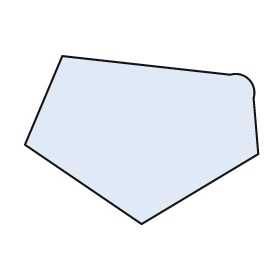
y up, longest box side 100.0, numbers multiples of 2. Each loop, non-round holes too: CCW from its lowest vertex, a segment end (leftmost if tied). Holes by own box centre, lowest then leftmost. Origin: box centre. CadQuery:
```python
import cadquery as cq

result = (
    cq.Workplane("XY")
    .moveTo(0.0, -36.0)
    .lineTo(50.0, -6.0)
    .lineTo(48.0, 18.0)
    .threePointArc((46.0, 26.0), (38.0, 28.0))
    .lineTo(-34.0, 36.0)
    .lineTo(-50.0, -2.0)
    .close()
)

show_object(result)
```